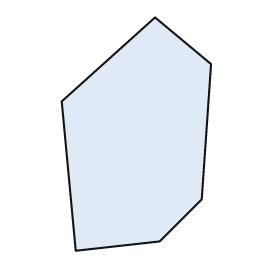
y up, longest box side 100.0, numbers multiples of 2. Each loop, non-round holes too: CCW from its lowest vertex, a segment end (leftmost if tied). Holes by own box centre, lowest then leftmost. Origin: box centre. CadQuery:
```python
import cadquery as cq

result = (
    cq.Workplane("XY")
    .moveTo(-26.0, -50.0)
    .lineTo(10.0, -46.0)
    .lineTo(28.0, -28.0)
    .lineTo(32.0, 30.0)
    .lineTo(8.0, 50.0)
    .lineTo(-32.0, 14.0)
    .close()
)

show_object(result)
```